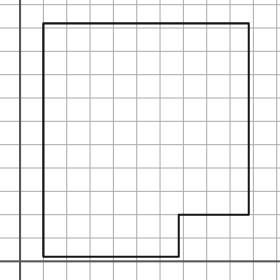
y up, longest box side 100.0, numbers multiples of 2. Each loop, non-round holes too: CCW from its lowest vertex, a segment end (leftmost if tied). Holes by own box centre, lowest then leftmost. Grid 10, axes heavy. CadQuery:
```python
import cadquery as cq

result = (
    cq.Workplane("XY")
    .moveTo(10.0, 2.0)
    .lineTo(68.0, 2.0)
    .lineTo(68.0, 20.0)
    .lineTo(98.0, 20.0)
    .lineTo(98.0, 102.0)
    .lineTo(10.0, 102.0)
    .close()
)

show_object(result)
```